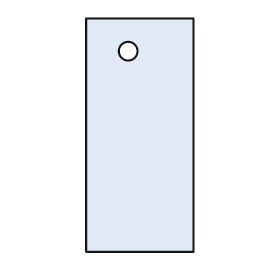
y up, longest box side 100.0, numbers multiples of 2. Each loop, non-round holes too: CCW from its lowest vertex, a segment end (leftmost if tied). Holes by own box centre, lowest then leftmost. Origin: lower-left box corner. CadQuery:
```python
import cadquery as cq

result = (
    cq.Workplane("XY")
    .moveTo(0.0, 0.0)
    .lineTo(46.0, 0.0)
    .lineTo(46.0, 100.0)
    .lineTo(0.0, 100.0)
    .close()
    .moveTo(18.0, 86.0)
    .circle(4.0)
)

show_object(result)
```